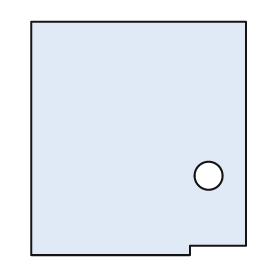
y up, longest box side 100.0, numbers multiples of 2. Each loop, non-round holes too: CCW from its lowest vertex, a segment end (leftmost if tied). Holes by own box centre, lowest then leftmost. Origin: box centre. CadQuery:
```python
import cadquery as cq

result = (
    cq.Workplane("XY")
    .moveTo(-46.0, -50.0)
    .lineTo(22.0, -50.0)
    .lineTo(22.0, -46.0)
    .lineTo(46.0, -46.0)
    .lineTo(46.0, 50.0)
    .lineTo(-46.0, 50.0)
    .close()
    .moveTo(30.0, -16.0)
    .circle(6.0)
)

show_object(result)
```